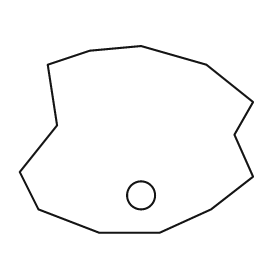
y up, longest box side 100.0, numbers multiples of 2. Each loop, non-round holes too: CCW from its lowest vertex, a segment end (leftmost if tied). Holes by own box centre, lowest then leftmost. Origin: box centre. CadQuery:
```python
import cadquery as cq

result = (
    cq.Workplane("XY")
    .moveTo(-16.0, -40.0)
    .lineTo(10.0, -40.0)
    .lineTo(32.0, -30.0)
    .lineTo(50.0, -16.0)
    .lineTo(42.0, 2.0)
    .lineTo(50.0, 16.0)
    .lineTo(30.0, 32.0)
    .lineTo(2.0, 40.0)
    .lineTo(-20.0, 38.0)
    .lineTo(-38.0, 32.0)
    .lineTo(-34.0, 6.0)
    .lineTo(-50.0, -14.0)
    .lineTo(-42.0, -30.0)
    .close()
    .moveTo(2.0, -24.0)
    .circle(6.0)
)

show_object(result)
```